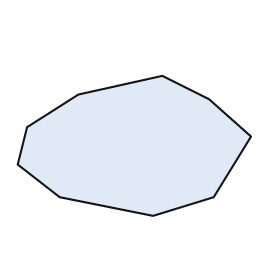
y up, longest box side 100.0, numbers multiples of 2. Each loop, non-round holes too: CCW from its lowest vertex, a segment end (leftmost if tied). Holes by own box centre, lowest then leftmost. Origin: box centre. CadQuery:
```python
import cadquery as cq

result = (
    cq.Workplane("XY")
    .moveTo(8.0, -30.0)
    .lineTo(34.0, -22.0)
    .lineTo(50.0, 4.0)
    .lineTo(32.0, 20.0)
    .lineTo(12.0, 30.0)
    .lineTo(-24.0, 22.0)
    .lineTo(-46.0, 8.0)
    .lineTo(-50.0, -8.0)
    .lineTo(-32.0, -22.0)
    .close()
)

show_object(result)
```